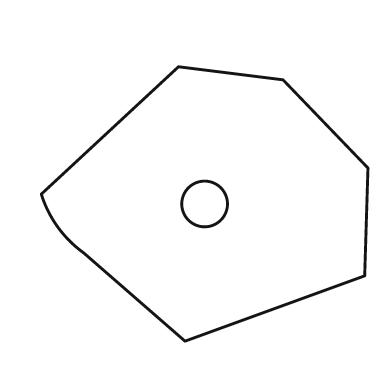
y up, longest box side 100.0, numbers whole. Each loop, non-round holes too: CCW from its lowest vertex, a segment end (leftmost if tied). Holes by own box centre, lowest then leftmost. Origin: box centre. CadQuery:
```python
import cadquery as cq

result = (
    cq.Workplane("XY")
    .moveTo(-6.0, -42.0)
    .lineTo(49.0, -22.0)
    .lineTo(50.0, 11.0)
    .lineTo(24.0, 38.0)
    .lineTo(-8.0, 42.0)
    .lineTo(-50.0, 3.0)
    .threePointArc((-45.0, -7.0), (-37.0, -15.0))
    .close()
    .moveTo(0.0, 0.0)
    .circle(7.0)
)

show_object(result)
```